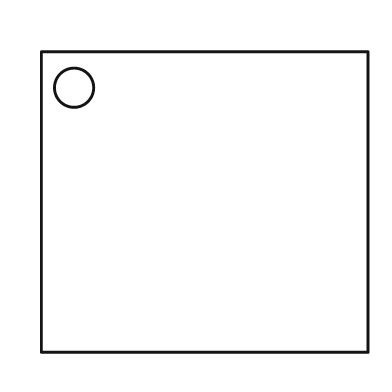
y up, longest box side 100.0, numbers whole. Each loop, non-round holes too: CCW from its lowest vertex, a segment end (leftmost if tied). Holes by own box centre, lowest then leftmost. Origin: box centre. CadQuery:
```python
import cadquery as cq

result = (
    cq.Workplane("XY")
    .moveTo(-50.0, -46.0)
    .lineTo(50.0, -46.0)
    .lineTo(50.0, 46.0)
    .lineTo(-50.0, 46.0)
    .close()
    .moveTo(-40.0, 35.0)
    .circle(6.0)
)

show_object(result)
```